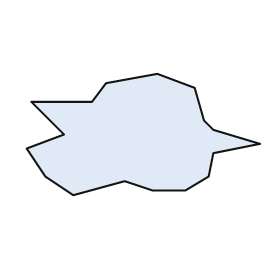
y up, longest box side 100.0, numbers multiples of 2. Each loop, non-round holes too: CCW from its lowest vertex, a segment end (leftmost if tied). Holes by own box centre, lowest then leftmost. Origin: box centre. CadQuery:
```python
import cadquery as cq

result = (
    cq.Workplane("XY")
    .moveTo(-30.0, -26.0)
    .lineTo(-8.0, -20.0)
    .lineTo(4.0, -24.0)
    .lineTo(18.0, -24.0)
    .lineTo(28.0, -18.0)
    .lineTo(30.0, -8.0)
    .lineTo(50.0, -4.0)
    .lineTo(30.0, 2.0)
    .lineTo(26.0, 6.0)
    .lineTo(22.0, 20.0)
    .lineTo(6.0, 26.0)
    .lineTo(-16.0, 22.0)
    .lineTo(-22.0, 14.0)
    .lineTo(-48.0, 14.0)
    .lineTo(-34.0, 0.0)
    .lineTo(-50.0, -6.0)
    .lineTo(-42.0, -18.0)
    .close()
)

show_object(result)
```